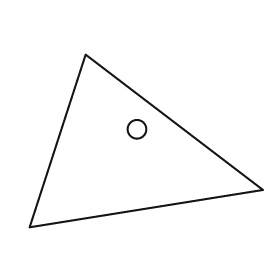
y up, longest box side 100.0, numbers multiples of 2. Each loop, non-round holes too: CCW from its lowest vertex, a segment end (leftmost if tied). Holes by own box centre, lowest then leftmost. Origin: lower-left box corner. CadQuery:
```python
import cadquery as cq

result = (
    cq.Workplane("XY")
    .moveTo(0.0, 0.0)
    .lineTo(100.0, 16.0)
    .lineTo(24.0, 74.0)
    .close()
    .moveTo(46.0, 42.0)
    .circle(4.0)
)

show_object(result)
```